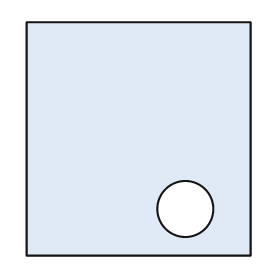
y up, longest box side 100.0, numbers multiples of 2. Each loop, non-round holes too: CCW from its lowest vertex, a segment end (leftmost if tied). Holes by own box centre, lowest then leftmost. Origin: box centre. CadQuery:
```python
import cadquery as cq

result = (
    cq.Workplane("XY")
    .moveTo(-48.0, -50.0)
    .lineTo(48.0, -50.0)
    .lineTo(48.0, 50.0)
    .lineTo(-48.0, 50.0)
    .close()
    .moveTo(20.0, -30.0)
    .circle(12.0)
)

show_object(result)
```